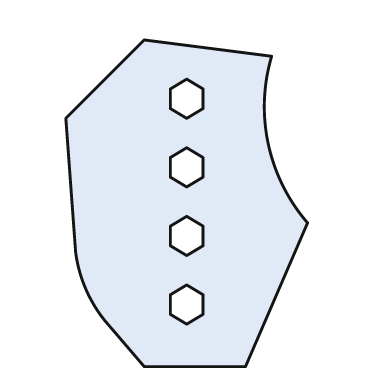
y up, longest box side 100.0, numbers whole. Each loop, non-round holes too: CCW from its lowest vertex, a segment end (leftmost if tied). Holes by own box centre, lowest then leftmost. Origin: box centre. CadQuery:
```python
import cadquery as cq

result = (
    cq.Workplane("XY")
    .moveTo(-13.0, -50.0)
    .lineTo(18.0, -50.0)
    .lineTo(37.0, -6.0)
    .threePointArc((25.0, 18.0), (26.0, 45.0))
    .lineTo(-13.0, 50.0)
    .lineTo(-37.0, 26.0)
    .lineTo(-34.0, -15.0)
    .threePointArc((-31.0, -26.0), (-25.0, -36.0))
    .close()
    .moveTo(0.0, -37.0)
    .lineTo(5.0, -34.0)
    .lineTo(5.0, -28.0)
    .lineTo(0.0, -25.0)
    .lineTo(-5.0, -28.0)
    .lineTo(-5.0, -34.0)
    .close()
    .moveTo(0.0, -16.0)
    .lineTo(5.0, -13.0)
    .lineTo(5.0, -7.0)
    .lineTo(0.0, -4.0)
    .lineTo(-5.0, -7.0)
    .lineTo(-5.0, -13.0)
    .close()
    .moveTo(0.0, 5.0)
    .lineTo(5.0, 8.0)
    .lineTo(5.0, 14.0)
    .lineTo(0.0, 17.0)
    .lineTo(-5.0, 14.0)
    .lineTo(-5.0, 8.0)
    .close()
    .moveTo(0.0, 26.0)
    .lineTo(5.0, 29.0)
    .lineTo(5.0, 35.0)
    .lineTo(0.0, 38.0)
    .lineTo(-5.0, 35.0)
    .lineTo(-5.0, 29.0)
    .close()
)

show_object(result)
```